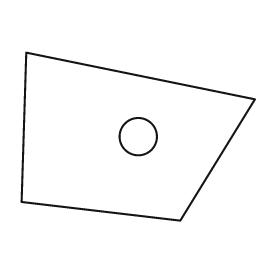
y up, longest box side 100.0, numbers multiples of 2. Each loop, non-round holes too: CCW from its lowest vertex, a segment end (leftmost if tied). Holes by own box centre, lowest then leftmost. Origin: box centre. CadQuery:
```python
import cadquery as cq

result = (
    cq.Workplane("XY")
    .moveTo(18.0, -36.0)
    .lineTo(50.0, 16.0)
    .lineTo(-48.0, 36.0)
    .lineTo(-50.0, -28.0)
    .close()
    .moveTo(0.0, 0.0)
    .circle(8.0)
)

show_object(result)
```